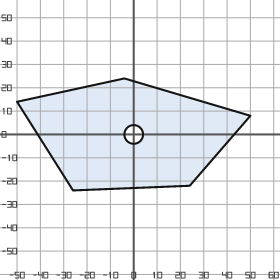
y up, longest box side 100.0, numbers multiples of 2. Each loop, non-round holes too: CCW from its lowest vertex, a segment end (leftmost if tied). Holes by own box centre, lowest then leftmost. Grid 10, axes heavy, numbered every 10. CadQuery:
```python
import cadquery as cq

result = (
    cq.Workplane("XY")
    .moveTo(-26.0, -24.0)
    .lineTo(24.0, -22.0)
    .lineTo(50.0, 8.0)
    .lineTo(-4.0, 24.0)
    .lineTo(-50.0, 14.0)
    .close()
    .moveTo(0.0, 0.0)
    .circle(4.0)
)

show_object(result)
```